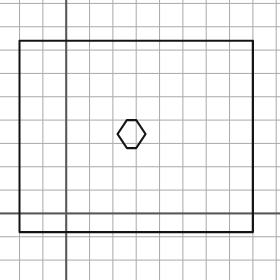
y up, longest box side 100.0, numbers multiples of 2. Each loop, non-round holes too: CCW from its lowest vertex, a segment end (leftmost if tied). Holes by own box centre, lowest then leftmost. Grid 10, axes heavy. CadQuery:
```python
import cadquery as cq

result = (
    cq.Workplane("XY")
    .moveTo(-20.0, -8.0)
    .lineTo(80.0, -8.0)
    .lineTo(80.0, 74.0)
    .lineTo(-20.0, 74.0)
    .close()
    .moveTo(26.0, 28.0)
    .lineTo(30.0, 28.0)
    .lineTo(34.0, 34.0)
    .lineTo(30.0, 40.0)
    .lineTo(26.0, 40.0)
    .lineTo(22.0, 34.0)
    .close()
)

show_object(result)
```